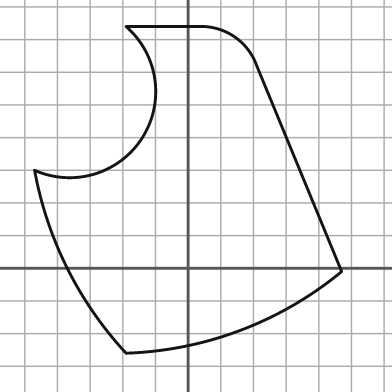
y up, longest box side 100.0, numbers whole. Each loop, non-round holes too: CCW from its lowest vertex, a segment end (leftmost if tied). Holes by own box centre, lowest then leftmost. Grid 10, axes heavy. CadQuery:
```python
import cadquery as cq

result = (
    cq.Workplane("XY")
    .moveTo(-19.0, -26.0)
    .threePointArc((16.0, -19.0), (47.0, -1.0))
    .lineTo(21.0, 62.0)
    .threePointArc((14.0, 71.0), (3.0, 74.0))
    .lineTo(-19.0, 74.0)
    .threePointArc((-14.0, 40.0), (-47.0, 30.0))
    .threePointArc((-37.0, 0.0), (-19.0, -26.0))
    .close()
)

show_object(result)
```